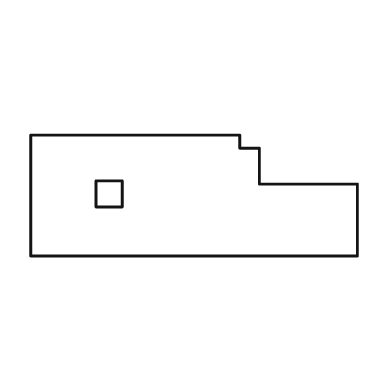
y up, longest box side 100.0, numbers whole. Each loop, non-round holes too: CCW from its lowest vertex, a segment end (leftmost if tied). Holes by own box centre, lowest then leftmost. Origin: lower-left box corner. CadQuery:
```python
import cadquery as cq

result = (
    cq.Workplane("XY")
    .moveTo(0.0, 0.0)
    .lineTo(100.0, 0.0)
    .lineTo(100.0, 22.0)
    .lineTo(70.0, 22.0)
    .lineTo(70.0, 33.0)
    .lineTo(64.0, 33.0)
    .lineTo(64.0, 37.0)
    .lineTo(0.0, 37.0)
    .close()
    .moveTo(20.0, 15.0)
    .lineTo(28.0, 15.0)
    .lineTo(28.0, 23.0)
    .lineTo(20.0, 23.0)
    .close()
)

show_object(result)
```